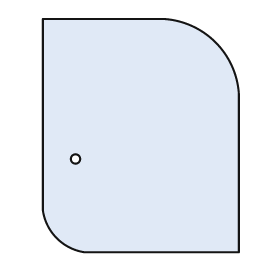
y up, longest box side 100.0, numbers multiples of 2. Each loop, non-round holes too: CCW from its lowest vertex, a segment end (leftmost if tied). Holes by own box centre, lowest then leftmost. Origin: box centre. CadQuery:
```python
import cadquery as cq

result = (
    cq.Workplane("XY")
    .moveTo(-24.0, -50.0)
    .lineTo(42.0, -50.0)
    .lineTo(42.0, 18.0)
    .threePointArc((32.0, 40.0), (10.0, 50.0))
    .lineTo(-42.0, 50.0)
    .lineTo(-42.0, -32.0)
    .threePointArc((-36.0, -44.0), (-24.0, -50.0))
    .close()
    .moveTo(-28.0, -10.0)
    .circle(2.0)
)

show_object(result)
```